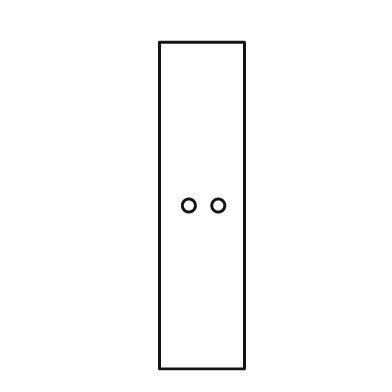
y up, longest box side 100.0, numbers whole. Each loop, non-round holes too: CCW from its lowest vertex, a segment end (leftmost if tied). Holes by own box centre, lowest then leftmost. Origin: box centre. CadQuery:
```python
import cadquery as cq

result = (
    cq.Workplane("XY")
    .moveTo(-13.0, -50.0)
    .lineTo(13.0, -50.0)
    .lineTo(13.0, 50.0)
    .lineTo(-13.0, 50.0)
    .close()
    .moveTo(-4.0, 0.0)
    .circle(2.0)
    .moveTo(5.0, 0.0)
    .circle(2.0)
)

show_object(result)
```